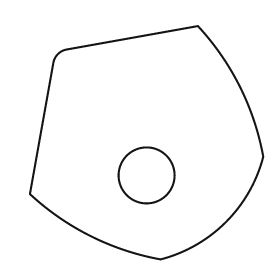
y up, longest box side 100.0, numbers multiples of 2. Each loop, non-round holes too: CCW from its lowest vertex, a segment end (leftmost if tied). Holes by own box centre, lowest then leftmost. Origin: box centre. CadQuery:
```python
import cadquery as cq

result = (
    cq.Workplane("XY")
    .moveTo(6.0, -50.0)
    .threePointArc((34.0, -34.0), (50.0, -6.0))
    .threePointArc((40.0, 24.0), (22.0, 50.0))
    .lineTo(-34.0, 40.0)
    .threePointArc((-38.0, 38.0), (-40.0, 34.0))
    .lineTo(-50.0, -22.0)
    .threePointArc((-24.0, -40.0), (6.0, -50.0))
    .close()
    .moveTo(0.0, -14.0)
    .circle(12.0)
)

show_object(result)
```